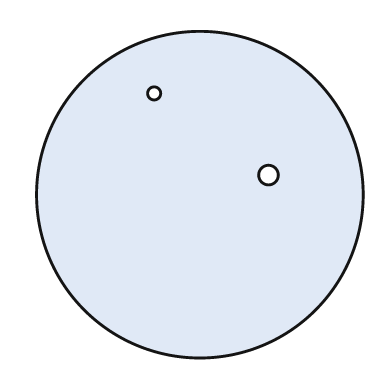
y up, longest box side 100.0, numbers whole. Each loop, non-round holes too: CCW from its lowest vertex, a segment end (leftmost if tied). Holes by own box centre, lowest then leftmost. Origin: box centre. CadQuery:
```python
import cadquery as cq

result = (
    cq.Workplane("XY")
    .moveTo(0.0, 0.0)
    .circle(50.0)
    .moveTo(21.0, 6.0)
    .circle(3.0)
    .moveTo(-14.0, 31.0)
    .circle(2.0)
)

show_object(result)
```